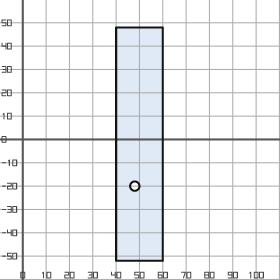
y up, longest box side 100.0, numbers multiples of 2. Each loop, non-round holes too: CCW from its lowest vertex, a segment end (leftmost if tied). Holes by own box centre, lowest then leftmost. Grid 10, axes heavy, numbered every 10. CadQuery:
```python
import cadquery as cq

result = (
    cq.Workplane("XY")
    .moveTo(40.0, -52.0)
    .lineTo(60.0, -52.0)
    .lineTo(60.0, 48.0)
    .lineTo(40.0, 48.0)
    .close()
    .moveTo(48.0, -20.0)
    .circle(2.0)
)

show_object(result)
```